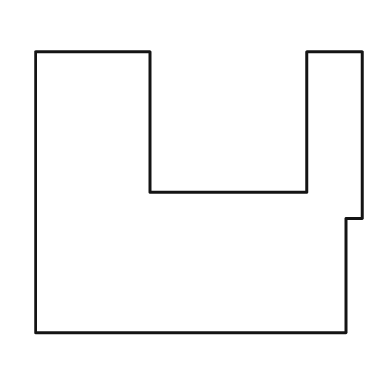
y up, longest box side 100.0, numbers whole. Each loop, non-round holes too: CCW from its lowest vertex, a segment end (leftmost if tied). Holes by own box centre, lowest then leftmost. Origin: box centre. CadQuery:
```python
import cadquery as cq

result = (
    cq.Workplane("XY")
    .moveTo(-50.0, -43.0)
    .lineTo(45.0, -43.0)
    .lineTo(45.0, -8.0)
    .lineTo(50.0, -8.0)
    .lineTo(50.0, 43.0)
    .lineTo(33.0, 43.0)
    .lineTo(33.0, 0.0)
    .lineTo(-15.0, 0.0)
    .lineTo(-15.0, 43.0)
    .lineTo(-50.0, 43.0)
    .close()
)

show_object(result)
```